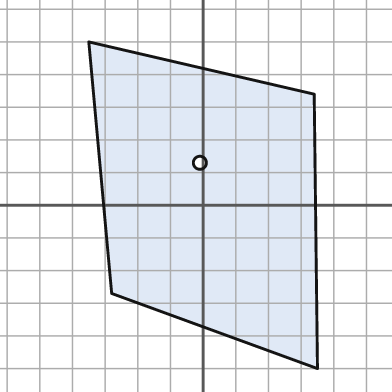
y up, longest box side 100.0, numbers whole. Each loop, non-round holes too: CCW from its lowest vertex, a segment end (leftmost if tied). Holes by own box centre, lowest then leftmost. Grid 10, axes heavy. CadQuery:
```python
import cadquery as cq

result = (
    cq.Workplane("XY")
    .moveTo(35.0, -50.0)
    .lineTo(34.0, 34.0)
    .lineTo(-35.0, 50.0)
    .lineTo(-28.0, -27.0)
    .close()
    .moveTo(-1.0, 13.0)
    .circle(2.0)
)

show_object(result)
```